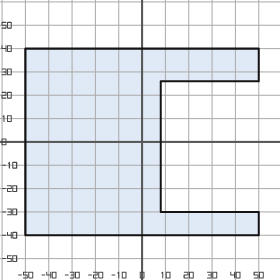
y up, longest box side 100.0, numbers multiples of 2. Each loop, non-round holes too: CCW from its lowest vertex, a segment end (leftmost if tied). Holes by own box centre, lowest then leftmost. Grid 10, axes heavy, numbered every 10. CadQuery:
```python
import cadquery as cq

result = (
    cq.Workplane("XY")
    .moveTo(-50.0, -40.0)
    .lineTo(50.0, -40.0)
    .lineTo(50.0, -30.0)
    .lineTo(8.0, -30.0)
    .lineTo(8.0, 26.0)
    .lineTo(50.0, 26.0)
    .lineTo(50.0, 40.0)
    .lineTo(-50.0, 40.0)
    .close()
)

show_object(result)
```